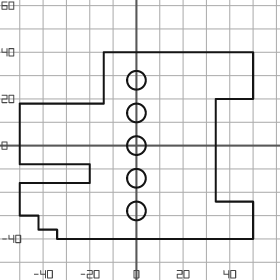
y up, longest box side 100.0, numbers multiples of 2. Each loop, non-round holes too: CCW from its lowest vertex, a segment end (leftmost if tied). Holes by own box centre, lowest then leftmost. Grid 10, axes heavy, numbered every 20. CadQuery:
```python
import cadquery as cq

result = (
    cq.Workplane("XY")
    .moveTo(-34.0, -40.0)
    .lineTo(50.0, -40.0)
    .lineTo(50.0, -24.0)
    .lineTo(34.0, -24.0)
    .lineTo(34.0, 20.0)
    .lineTo(50.0, 20.0)
    .lineTo(50.0, 40.0)
    .lineTo(-14.0, 40.0)
    .lineTo(-14.0, 18.0)
    .lineTo(-50.0, 18.0)
    .lineTo(-50.0, -8.0)
    .lineTo(-20.0, -8.0)
    .lineTo(-20.0, -16.0)
    .lineTo(-50.0, -16.0)
    .lineTo(-50.0, -30.0)
    .lineTo(-42.0, -30.0)
    .lineTo(-42.0, -36.0)
    .lineTo(-34.0, -36.0)
    .close()
    .moveTo(0.0, -28.0)
    .circle(4.0)
    .moveTo(0.0, -14.0)
    .circle(4.0)
    .moveTo(0.0, 0.0)
    .circle(4.0)
    .moveTo(0.0, 14.0)
    .circle(4.0)
    .moveTo(0.0, 28.0)
    .circle(4.0)
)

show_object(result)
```